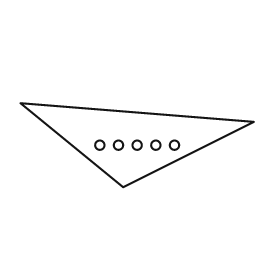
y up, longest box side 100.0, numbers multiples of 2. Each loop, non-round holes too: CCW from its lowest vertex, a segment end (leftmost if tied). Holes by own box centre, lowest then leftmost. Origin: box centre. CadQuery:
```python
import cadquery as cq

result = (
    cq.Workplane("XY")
    .moveTo(-6.0, -18.0)
    .lineTo(50.0, 10.0)
    .lineTo(-50.0, 18.0)
    .close()
    .moveTo(-16.0, 0.0)
    .circle(2.0)
    .moveTo(-8.0, 0.0)
    .circle(2.0)
    .moveTo(0.0, 0.0)
    .circle(2.0)
    .moveTo(8.0, 0.0)
    .circle(2.0)
    .moveTo(16.0, 0.0)
    .circle(2.0)
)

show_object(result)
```